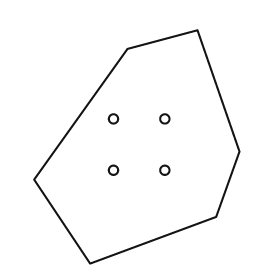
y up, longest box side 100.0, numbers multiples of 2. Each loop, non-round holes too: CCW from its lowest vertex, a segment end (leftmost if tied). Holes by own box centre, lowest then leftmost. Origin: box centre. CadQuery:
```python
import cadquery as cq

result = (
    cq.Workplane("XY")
    .moveTo(-20.0, -50.0)
    .lineTo(34.0, -30.0)
    .lineTo(44.0, -2.0)
    .lineTo(26.0, 50.0)
    .lineTo(-4.0, 42.0)
    .lineTo(-44.0, -14.0)
    .close()
    .moveTo(-10.0, -10.0)
    .circle(2.0)
    .moveTo(12.0, -10.0)
    .circle(2.0)
    .moveTo(-10.0, 12.0)
    .circle(2.0)
    .moveTo(12.0, 12.0)
    .circle(2.0)
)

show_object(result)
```